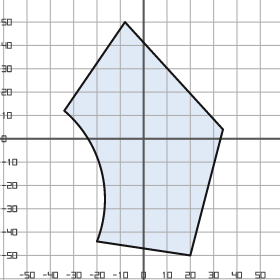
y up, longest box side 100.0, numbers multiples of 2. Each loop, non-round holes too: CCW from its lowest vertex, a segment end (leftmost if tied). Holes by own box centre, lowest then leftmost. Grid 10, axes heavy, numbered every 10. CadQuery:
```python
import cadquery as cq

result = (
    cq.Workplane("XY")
    .moveTo(20.0, -50.0)
    .lineTo(34.0, 4.0)
    .lineTo(-8.0, 50.0)
    .lineTo(-34.0, 12.0)
    .threePointArc((-18.0, -14.0), (-20.0, -44.0))
    .close()
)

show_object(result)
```